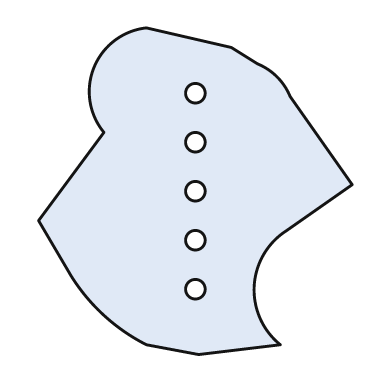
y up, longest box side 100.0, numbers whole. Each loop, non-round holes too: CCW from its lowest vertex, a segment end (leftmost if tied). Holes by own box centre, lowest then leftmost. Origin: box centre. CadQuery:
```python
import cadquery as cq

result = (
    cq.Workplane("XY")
    .moveTo(1.0, -50.0)
    .lineTo(26.0, -47.0)
    .threePointArc((18.0, -29.0), (28.0, -12.0))
    .lineTo(48.0, 2.0)
    .lineTo(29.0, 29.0)
    .threePointArc((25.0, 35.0), (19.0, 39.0))
    .lineTo(11.0, 44.0)
    .lineTo(-15.0, 50.0)
    .threePointArc((-31.0, 38.0), (-28.0, 18.0))
    .lineTo(-48.0, -9.0)
    .lineTo(-38.0, -26.0)
    .threePointArc((-28.0, -38.0), (-15.0, -47.0))
    .close()
    .moveTo(0.0, -30.0)
    .circle(3.0)
    .moveTo(0.0, -15.0)
    .circle(3.0)
    .moveTo(0.0, 0.0)
    .circle(3.0)
    .moveTo(0.0, 15.0)
    .circle(3.0)
    .moveTo(0.0, 30.0)
    .circle(3.0)
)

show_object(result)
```